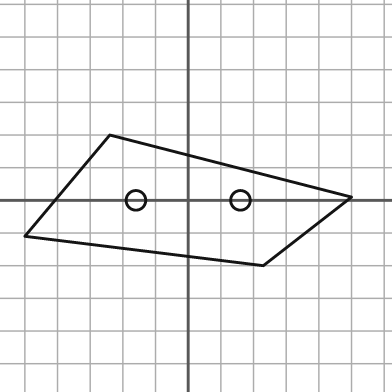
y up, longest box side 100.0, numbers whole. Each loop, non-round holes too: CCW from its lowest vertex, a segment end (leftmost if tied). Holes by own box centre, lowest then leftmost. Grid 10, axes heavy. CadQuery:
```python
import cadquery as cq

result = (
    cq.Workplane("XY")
    .moveTo(23.0, -20.0)
    .lineTo(50.0, 1.0)
    .lineTo(-24.0, 20.0)
    .lineTo(-50.0, -11.0)
    .close()
    .moveTo(-16.0, 0.0)
    .circle(3.0)
    .moveTo(16.0, 0.0)
    .circle(3.0)
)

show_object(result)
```